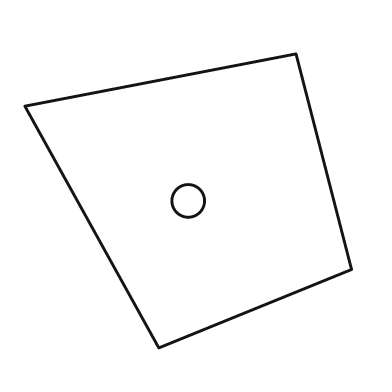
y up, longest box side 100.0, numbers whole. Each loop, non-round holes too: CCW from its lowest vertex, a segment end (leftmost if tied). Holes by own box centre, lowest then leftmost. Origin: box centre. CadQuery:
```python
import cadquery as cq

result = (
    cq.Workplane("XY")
    .moveTo(-9.0, -45.0)
    .lineTo(50.0, -21.0)
    .lineTo(33.0, 45.0)
    .lineTo(-50.0, 29.0)
    .close()
    .moveTo(0.0, 0.0)
    .circle(5.0)
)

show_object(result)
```